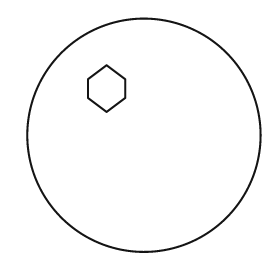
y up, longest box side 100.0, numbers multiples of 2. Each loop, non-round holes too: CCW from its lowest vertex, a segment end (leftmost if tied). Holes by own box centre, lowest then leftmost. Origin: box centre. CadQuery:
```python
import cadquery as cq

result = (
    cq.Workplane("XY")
    .moveTo(0.0, 0.0)
    .circle(50.0)
    .moveTo(-16.0, 10.0)
    .lineTo(-8.0, 16.0)
    .lineTo(-8.0, 24.0)
    .lineTo(-16.0, 30.0)
    .lineTo(-24.0, 24.0)
    .lineTo(-24.0, 16.0)
    .close()
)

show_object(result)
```